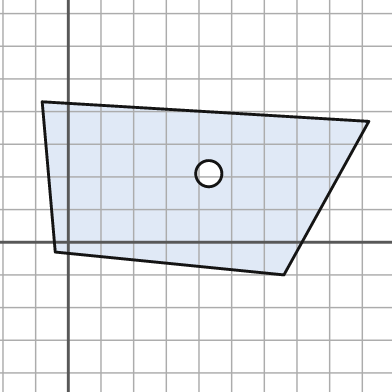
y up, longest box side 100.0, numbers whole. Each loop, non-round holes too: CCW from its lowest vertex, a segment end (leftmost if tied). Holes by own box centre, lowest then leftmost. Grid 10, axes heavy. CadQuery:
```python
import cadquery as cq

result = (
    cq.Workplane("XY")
    .moveTo(66.0, -10.0)
    .lineTo(92.0, 37.0)
    .lineTo(-8.0, 43.0)
    .lineTo(-4.0, -3.0)
    .close()
    .moveTo(43.0, 21.0)
    .circle(4.0)
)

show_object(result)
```